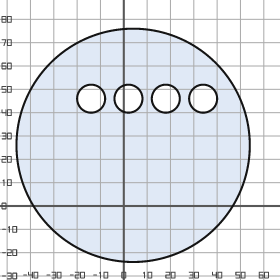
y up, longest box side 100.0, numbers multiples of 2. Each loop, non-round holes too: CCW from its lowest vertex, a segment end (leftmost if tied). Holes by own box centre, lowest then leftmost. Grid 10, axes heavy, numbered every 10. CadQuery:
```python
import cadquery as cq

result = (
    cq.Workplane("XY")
    .moveTo(4.0, 26.0)
    .circle(50.0)
    .moveTo(-14.0, 46.0)
    .circle(6.0)
    .moveTo(2.0, 46.0)
    .circle(6.0)
    .moveTo(18.0, 46.0)
    .circle(6.0)
    .moveTo(34.0, 46.0)
    .circle(6.0)
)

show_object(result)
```